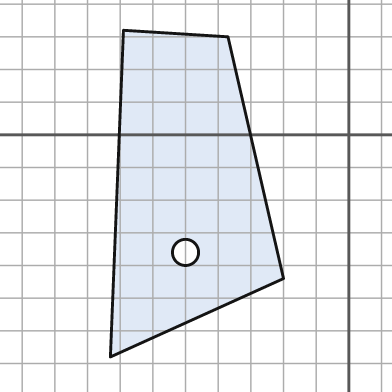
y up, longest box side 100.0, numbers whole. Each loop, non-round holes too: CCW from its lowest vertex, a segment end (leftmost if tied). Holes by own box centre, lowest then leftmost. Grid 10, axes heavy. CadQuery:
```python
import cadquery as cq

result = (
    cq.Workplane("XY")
    .moveTo(-73.0, -68.0)
    .lineTo(-20.0, -44.0)
    .lineTo(-37.0, 30.0)
    .lineTo(-69.0, 32.0)
    .close()
    .moveTo(-50.0, -36.0)
    .circle(4.0)
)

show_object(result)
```